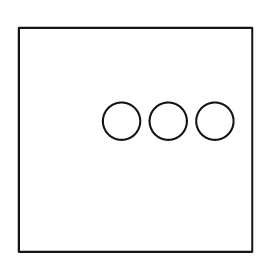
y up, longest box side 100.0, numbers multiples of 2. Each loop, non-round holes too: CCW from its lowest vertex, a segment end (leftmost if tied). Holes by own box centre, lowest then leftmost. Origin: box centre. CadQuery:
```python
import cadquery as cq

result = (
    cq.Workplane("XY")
    .moveTo(-50.0, -48.0)
    .lineTo(50.0, -48.0)
    .lineTo(50.0, 48.0)
    .lineTo(-50.0, 48.0)
    .close()
    .moveTo(-6.0, 8.0)
    .circle(8.0)
    .moveTo(14.0, 8.0)
    .circle(8.0)
    .moveTo(34.0, 8.0)
    .circle(8.0)
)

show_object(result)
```